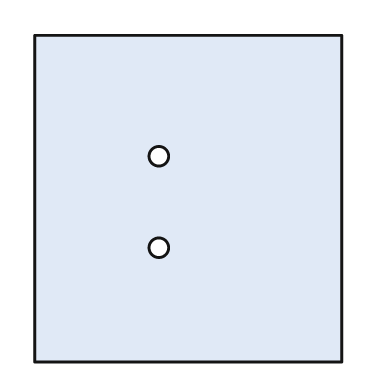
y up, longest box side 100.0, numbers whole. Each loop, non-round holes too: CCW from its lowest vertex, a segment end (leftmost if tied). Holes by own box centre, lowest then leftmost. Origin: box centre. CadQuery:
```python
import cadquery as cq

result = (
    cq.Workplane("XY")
    .moveTo(-47.0, -50.0)
    .lineTo(47.0, -50.0)
    .lineTo(47.0, 50.0)
    .lineTo(-47.0, 50.0)
    .close()
    .moveTo(-9.0, -15.0)
    .circle(3.0)
    .moveTo(-9.0, 13.0)
    .circle(3.0)
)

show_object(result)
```